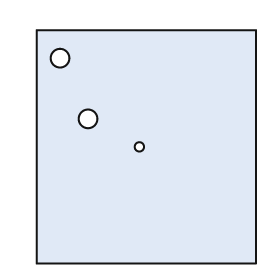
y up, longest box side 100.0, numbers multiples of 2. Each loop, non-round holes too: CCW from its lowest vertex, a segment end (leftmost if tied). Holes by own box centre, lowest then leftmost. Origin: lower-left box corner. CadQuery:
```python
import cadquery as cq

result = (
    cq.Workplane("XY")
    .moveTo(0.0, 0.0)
    .lineTo(94.0, 0.0)
    .lineTo(94.0, 100.0)
    .lineTo(0.0, 100.0)
    .close()
    .moveTo(44.0, 50.0)
    .circle(2.0)
    .moveTo(22.0, 62.0)
    .circle(4.0)
    .moveTo(10.0, 88.0)
    .circle(4.0)
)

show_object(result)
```